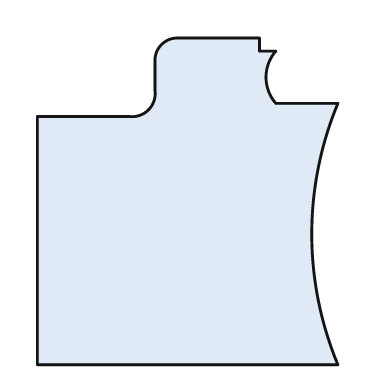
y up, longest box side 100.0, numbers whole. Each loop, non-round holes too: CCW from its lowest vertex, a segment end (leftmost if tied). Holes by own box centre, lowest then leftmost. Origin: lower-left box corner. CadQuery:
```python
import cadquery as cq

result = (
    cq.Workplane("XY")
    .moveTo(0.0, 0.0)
    .lineTo(92.0, 0.0)
    .threePointArc((84.0, 40.0), (92.0, 80.0))
    .lineTo(73.0, 80.0)
    .threePointArc((70.0, 88.0), (73.0, 96.0))
    .lineTo(68.0, 96.0)
    .lineTo(68.0, 100.0)
    .lineTo(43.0, 100.0)
    .threePointArc((38.0, 98.0), (36.0, 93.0))
    .lineTo(36.0, 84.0)
    .threePointArc((34.0, 78.0), (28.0, 76.0))
    .lineTo(0.0, 76.0)
    .close()
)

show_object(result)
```